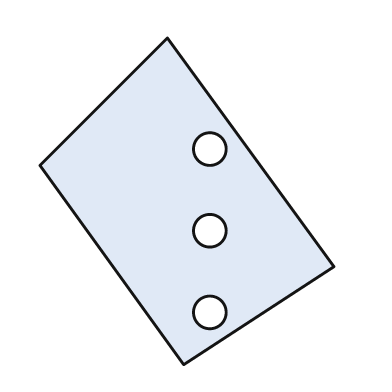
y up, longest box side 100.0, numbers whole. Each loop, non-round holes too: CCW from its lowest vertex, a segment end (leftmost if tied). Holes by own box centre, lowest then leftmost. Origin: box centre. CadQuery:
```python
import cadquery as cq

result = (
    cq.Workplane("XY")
    .moveTo(-1.0, -50.0)
    .lineTo(45.0, -20.0)
    .lineTo(-6.0, 50.0)
    .lineTo(-45.0, 11.0)
    .close()
    .moveTo(7.0, -34.0)
    .circle(5.0)
    .moveTo(7.0, -9.0)
    .circle(5.0)
    .moveTo(7.0, 16.0)
    .circle(5.0)
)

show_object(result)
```